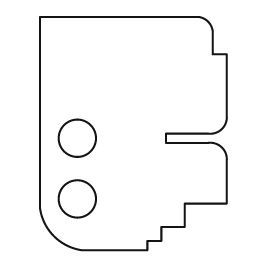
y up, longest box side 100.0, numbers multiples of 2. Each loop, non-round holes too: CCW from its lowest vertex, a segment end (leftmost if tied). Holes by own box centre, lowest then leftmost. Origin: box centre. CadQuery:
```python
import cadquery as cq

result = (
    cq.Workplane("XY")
    .moveTo(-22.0, -50.0)
    .lineTo(6.0, -50.0)
    .lineTo(6.0, -46.0)
    .lineTo(12.0, -46.0)
    .lineTo(12.0, -40.0)
    .lineTo(22.0, -40.0)
    .lineTo(22.0, -30.0)
    .lineTo(40.0, -30.0)
    .lineTo(40.0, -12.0)
    .threePointArc((38.0, -6.0), (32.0, -4.0))
    .lineTo(14.0, -4.0)
    .lineTo(14.0, 0.0)
    .lineTo(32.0, 0.0)
    .threePointArc((38.0, 2.0), (40.0, 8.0))
    .lineTo(40.0, 34.0)
    .lineTo(34.0, 34.0)
    .lineTo(34.0, 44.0)
    .threePointArc((32.0, 48.0), (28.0, 50.0))
    .lineTo(-40.0, 50.0)
    .lineTo(-40.0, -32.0)
    .threePointArc((-34.0, -44.0), (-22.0, -50.0))
    .close()
    .moveTo(-24.0, -28.0)
    .circle(8.0)
    .moveTo(-24.0, -2.0)
    .circle(8.0)
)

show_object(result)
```